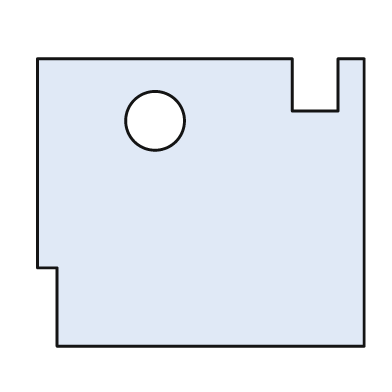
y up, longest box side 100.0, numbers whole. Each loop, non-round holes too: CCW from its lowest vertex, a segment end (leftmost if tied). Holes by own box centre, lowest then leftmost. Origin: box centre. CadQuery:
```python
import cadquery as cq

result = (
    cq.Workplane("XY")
    .moveTo(-44.0, -44.0)
    .lineTo(50.0, -44.0)
    .lineTo(50.0, 44.0)
    .lineTo(42.0, 44.0)
    .lineTo(42.0, 28.0)
    .lineTo(28.0, 28.0)
    .lineTo(28.0, 44.0)
    .lineTo(-50.0, 44.0)
    .lineTo(-50.0, -20.0)
    .lineTo(-44.0, -20.0)
    .close()
    .moveTo(-14.0, 25.0)
    .circle(9.0)
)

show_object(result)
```